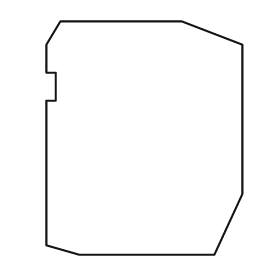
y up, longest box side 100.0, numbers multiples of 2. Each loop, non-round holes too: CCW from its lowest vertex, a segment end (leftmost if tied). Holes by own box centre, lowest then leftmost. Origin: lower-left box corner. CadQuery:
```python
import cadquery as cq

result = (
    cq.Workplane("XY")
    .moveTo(14.0, 0.0)
    .lineTo(72.0, 0.0)
    .lineTo(84.0, 26.0)
    .lineTo(84.0, 90.0)
    .lineTo(58.0, 100.0)
    .lineTo(6.0, 100.0)
    .lineTo(0.0, 90.0)
    .lineTo(0.0, 78.0)
    .lineTo(4.0, 78.0)
    .lineTo(4.0, 66.0)
    .lineTo(0.0, 66.0)
    .lineTo(0.0, 4.0)
    .close()
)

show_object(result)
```